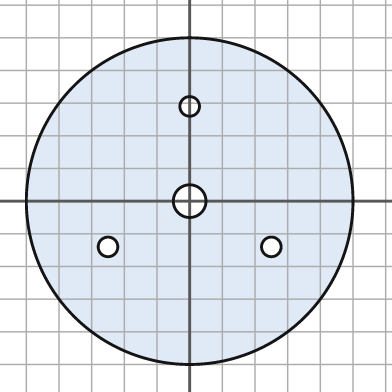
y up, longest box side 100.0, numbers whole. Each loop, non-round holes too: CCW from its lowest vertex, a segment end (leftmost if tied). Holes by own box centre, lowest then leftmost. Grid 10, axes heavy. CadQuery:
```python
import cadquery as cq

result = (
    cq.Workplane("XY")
    .moveTo(0.0, 0.0)
    .circle(50.0)
    .moveTo(-25.0, -14.0)
    .circle(3.0)
    .moveTo(25.0, -14.0)
    .circle(3.0)
    .moveTo(0.0, 0.0)
    .circle(5.0)
    .moveTo(0.0, 29.0)
    .circle(3.0)
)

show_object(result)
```